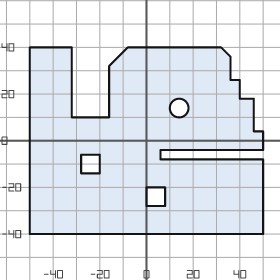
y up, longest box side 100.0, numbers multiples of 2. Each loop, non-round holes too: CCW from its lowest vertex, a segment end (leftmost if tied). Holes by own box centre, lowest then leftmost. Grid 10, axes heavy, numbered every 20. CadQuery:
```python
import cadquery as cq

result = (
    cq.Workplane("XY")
    .moveTo(-50.0, -40.0)
    .lineTo(50.0, -40.0)
    .lineTo(50.0, -8.0)
    .lineTo(6.0, -8.0)
    .lineTo(6.0, -4.0)
    .lineTo(50.0, -4.0)
    .lineTo(50.0, 4.0)
    .lineTo(46.0, 4.0)
    .lineTo(46.0, 18.0)
    .lineTo(40.0, 18.0)
    .lineTo(40.0, 26.0)
    .lineTo(36.0, 26.0)
    .lineTo(36.0, 36.0)
    .lineTo(32.0, 40.0)
    .lineTo(-8.0, 40.0)
    .lineTo(-16.0, 32.0)
    .lineTo(-16.0, 10.0)
    .lineTo(-32.0, 10.0)
    .lineTo(-32.0, 40.0)
    .lineTo(-50.0, 40.0)
    .close()
    .moveTo(0.0, -28.0)
    .lineTo(8.0, -28.0)
    .lineTo(8.0, -20.0)
    .lineTo(0.0, -20.0)
    .close()
    .moveTo(-28.0, -14.0)
    .lineTo(-20.0, -14.0)
    .lineTo(-20.0, -6.0)
    .lineTo(-28.0, -6.0)
    .close()
    .moveTo(14.0, 14.0)
    .circle(4.0)
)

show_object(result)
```